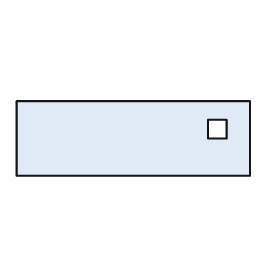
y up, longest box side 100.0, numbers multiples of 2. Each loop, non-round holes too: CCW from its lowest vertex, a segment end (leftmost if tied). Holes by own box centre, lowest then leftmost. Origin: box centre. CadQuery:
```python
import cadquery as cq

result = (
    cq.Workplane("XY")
    .moveTo(-50.0, -16.0)
    .lineTo(50.0, -16.0)
    .lineTo(50.0, 16.0)
    .lineTo(-50.0, 16.0)
    .close()
    .moveTo(32.0, 0.0)
    .lineTo(40.0, 0.0)
    .lineTo(40.0, 8.0)
    .lineTo(32.0, 8.0)
    .close()
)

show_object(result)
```